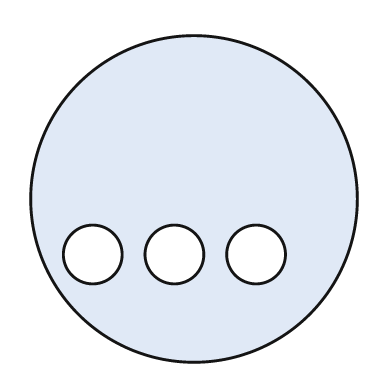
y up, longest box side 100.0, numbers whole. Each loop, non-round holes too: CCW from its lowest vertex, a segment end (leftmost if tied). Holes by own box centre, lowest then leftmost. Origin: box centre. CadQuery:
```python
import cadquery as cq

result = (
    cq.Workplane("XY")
    .moveTo(0.0, 0.0)
    .circle(50.0)
    .moveTo(-31.0, -17.0)
    .circle(9.0)
    .moveTo(-6.0, -17.0)
    .circle(9.0)
    .moveTo(19.0, -17.0)
    .circle(9.0)
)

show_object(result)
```